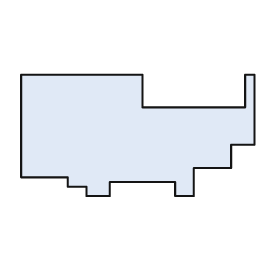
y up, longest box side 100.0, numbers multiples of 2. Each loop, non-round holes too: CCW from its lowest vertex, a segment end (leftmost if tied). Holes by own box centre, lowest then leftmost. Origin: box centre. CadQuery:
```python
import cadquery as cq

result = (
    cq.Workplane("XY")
    .moveTo(-22.0, -26.0)
    .lineTo(-12.0, -26.0)
    .lineTo(-12.0, -20.0)
    .lineTo(16.0, -20.0)
    .lineTo(16.0, -26.0)
    .lineTo(24.0, -26.0)
    .lineTo(24.0, -14.0)
    .lineTo(40.0, -14.0)
    .lineTo(40.0, -4.0)
    .lineTo(50.0, -4.0)
    .lineTo(50.0, 26.0)
    .lineTo(46.0, 26.0)
    .lineTo(46.0, 12.0)
    .lineTo(2.0, 12.0)
    .lineTo(2.0, 26.0)
    .lineTo(-50.0, 26.0)
    .lineTo(-50.0, -18.0)
    .lineTo(-30.0, -18.0)
    .lineTo(-30.0, -22.0)
    .lineTo(-22.0, -22.0)
    .close()
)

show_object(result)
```